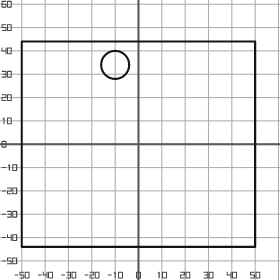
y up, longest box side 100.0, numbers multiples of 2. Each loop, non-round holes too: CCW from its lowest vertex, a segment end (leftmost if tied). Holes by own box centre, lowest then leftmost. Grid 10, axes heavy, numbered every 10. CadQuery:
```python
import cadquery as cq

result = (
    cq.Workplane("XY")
    .moveTo(-50.0, -44.0)
    .lineTo(50.0, -44.0)
    .lineTo(50.0, 44.0)
    .lineTo(-50.0, 44.0)
    .close()
    .moveTo(-10.0, 34.0)
    .circle(6.0)
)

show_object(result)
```